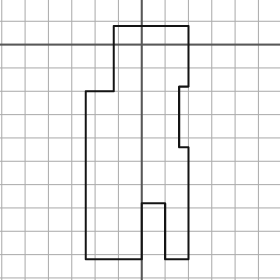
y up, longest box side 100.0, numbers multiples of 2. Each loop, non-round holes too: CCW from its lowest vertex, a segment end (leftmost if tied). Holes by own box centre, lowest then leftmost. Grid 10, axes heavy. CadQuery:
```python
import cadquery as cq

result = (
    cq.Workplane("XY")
    .moveTo(-24.0, -92.0)
    .lineTo(0.0, -92.0)
    .lineTo(0.0, -68.0)
    .lineTo(10.0, -68.0)
    .lineTo(10.0, -92.0)
    .lineTo(20.0, -92.0)
    .lineTo(20.0, -44.0)
    .lineTo(16.0, -44.0)
    .lineTo(16.0, -18.0)
    .lineTo(20.0, -18.0)
    .lineTo(20.0, 8.0)
    .lineTo(-12.0, 8.0)
    .lineTo(-12.0, -20.0)
    .lineTo(-24.0, -20.0)
    .close()
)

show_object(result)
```